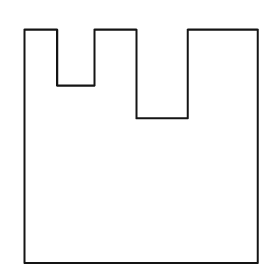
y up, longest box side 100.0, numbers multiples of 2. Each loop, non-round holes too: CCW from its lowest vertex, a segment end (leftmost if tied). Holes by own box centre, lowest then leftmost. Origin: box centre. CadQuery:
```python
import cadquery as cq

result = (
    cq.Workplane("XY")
    .moveTo(-50.0, -50.0)
    .lineTo(50.0, -50.0)
    .lineTo(50.0, 50.0)
    .lineTo(20.0, 50.0)
    .lineTo(20.0, 12.0)
    .lineTo(-2.0, 12.0)
    .lineTo(-2.0, 50.0)
    .lineTo(-20.0, 50.0)
    .lineTo(-20.0, 26.0)
    .lineTo(-36.0, 26.0)
    .lineTo(-36.0, 50.0)
    .lineTo(-50.0, 50.0)
    .close()
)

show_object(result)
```